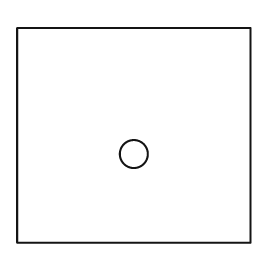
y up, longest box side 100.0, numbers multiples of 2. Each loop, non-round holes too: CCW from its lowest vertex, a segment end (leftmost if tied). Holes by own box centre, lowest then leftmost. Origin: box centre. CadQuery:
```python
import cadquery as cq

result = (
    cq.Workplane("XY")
    .moveTo(-50.0, -46.0)
    .lineTo(50.0, -46.0)
    .lineTo(50.0, 46.0)
    .lineTo(-50.0, 46.0)
    .close()
    .moveTo(0.0, -8.0)
    .circle(6.0)
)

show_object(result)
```